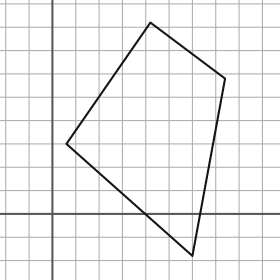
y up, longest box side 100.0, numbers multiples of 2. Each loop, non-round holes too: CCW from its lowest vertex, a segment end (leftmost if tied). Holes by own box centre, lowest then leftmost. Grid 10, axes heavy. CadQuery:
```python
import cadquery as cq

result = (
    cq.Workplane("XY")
    .moveTo(60.0, -18.0)
    .lineTo(74.0, 58.0)
    .lineTo(42.0, 82.0)
    .lineTo(6.0, 30.0)
    .close()
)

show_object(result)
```